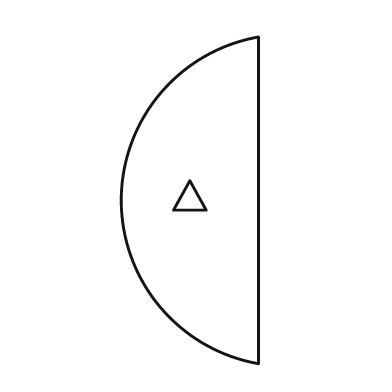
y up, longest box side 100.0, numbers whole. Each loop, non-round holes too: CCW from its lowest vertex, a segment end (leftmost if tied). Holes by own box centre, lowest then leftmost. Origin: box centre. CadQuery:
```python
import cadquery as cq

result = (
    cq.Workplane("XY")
    .moveTo(21.0, -50.0)
    .lineTo(21.0, 50.0)
    .threePointArc((-21.0, 0.0), (21.0, -50.0))
    .close()
    .moveTo(-5.0, -3.0)
    .lineTo(5.0, -3.0)
    .lineTo(0.0, 6.0)
    .close()
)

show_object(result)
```